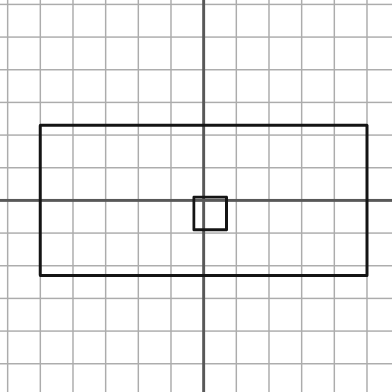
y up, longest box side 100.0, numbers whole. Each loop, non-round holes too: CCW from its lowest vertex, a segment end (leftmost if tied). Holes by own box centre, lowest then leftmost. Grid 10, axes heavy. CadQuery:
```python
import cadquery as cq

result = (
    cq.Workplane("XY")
    .moveTo(-50.0, -23.0)
    .lineTo(50.0, -23.0)
    .lineTo(50.0, 23.0)
    .lineTo(-50.0, 23.0)
    .close()
    .moveTo(-3.0, -9.0)
    .lineTo(7.0, -9.0)
    .lineTo(7.0, 1.0)
    .lineTo(-3.0, 1.0)
    .close()
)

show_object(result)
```